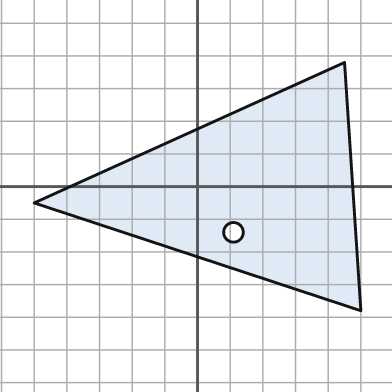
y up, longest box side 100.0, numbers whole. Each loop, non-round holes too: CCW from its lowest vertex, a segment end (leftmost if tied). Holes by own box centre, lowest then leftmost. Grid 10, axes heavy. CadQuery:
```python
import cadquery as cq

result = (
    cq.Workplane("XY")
    .moveTo(50.0, -38.0)
    .lineTo(45.0, 38.0)
    .lineTo(-50.0, -5.0)
    .close()
    .moveTo(11.0, -14.0)
    .circle(3.0)
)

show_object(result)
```